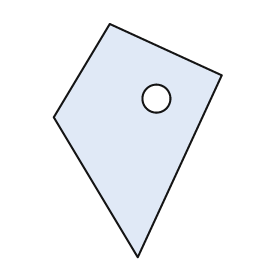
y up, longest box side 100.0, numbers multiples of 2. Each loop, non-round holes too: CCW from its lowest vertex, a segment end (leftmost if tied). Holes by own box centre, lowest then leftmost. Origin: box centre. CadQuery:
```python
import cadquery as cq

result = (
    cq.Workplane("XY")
    .moveTo(0.0, -50.0)
    .lineTo(36.0, 28.0)
    .lineTo(-12.0, 50.0)
    .lineTo(-36.0, 10.0)
    .close()
    .moveTo(8.0, 18.0)
    .circle(6.0)
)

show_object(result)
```